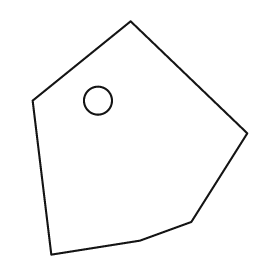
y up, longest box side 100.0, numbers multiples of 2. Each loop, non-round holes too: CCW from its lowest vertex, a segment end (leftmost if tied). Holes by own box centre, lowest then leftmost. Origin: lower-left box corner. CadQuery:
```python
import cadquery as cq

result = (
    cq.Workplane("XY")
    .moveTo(8.0, 0.0)
    .lineTo(46.0, 6.0)
    .lineTo(68.0, 14.0)
    .lineTo(92.0, 52.0)
    .lineTo(42.0, 100.0)
    .lineTo(0.0, 66.0)
    .close()
    .moveTo(28.0, 66.0)
    .circle(6.0)
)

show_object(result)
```